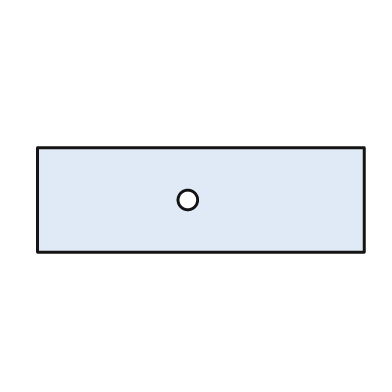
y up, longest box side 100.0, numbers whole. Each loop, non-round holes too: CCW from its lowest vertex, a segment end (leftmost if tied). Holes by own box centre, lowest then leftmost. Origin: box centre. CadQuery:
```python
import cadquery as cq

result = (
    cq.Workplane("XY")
    .moveTo(-50.0, -16.0)
    .lineTo(50.0, -16.0)
    .lineTo(50.0, 16.0)
    .lineTo(-50.0, 16.0)
    .close()
    .moveTo(-4.0, 0.0)
    .circle(3.0)
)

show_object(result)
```